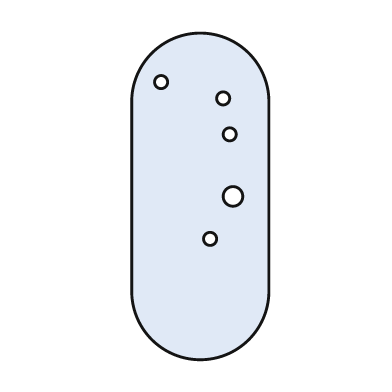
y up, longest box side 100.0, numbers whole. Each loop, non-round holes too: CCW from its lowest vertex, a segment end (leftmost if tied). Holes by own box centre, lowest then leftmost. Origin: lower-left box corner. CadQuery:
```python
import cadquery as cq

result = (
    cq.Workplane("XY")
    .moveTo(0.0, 21.0)
    .threePointArc((21.0, 0.0), (42.0, 21.0))
    .lineTo(42.0, 79.0)
    .threePointArc((21.0, 100.0), (0.0, 79.0))
    .close()
    .moveTo(24.0, 37.0)
    .circle(2.0)
    .moveTo(31.0, 50.0)
    .circle(3.0)
    .moveTo(30.0, 69.0)
    .circle(2.0)
    .moveTo(28.0, 80.0)
    .circle(2.0)
    .moveTo(9.0, 85.0)
    .circle(2.0)
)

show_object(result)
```